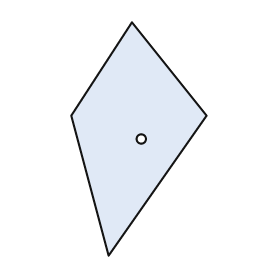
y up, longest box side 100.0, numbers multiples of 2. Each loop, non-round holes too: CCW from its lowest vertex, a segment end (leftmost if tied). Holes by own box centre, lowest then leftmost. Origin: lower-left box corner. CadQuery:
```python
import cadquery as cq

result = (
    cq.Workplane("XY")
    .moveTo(16.0, 0.0)
    .lineTo(58.0, 60.0)
    .lineTo(26.0, 100.0)
    .lineTo(0.0, 60.0)
    .close()
    .moveTo(30.0, 50.0)
    .circle(2.0)
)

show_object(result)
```